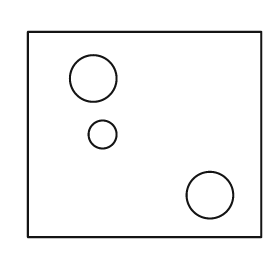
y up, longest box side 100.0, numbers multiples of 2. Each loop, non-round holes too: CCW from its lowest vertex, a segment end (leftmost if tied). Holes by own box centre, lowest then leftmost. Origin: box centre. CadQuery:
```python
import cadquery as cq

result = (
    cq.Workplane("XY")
    .moveTo(-50.0, -44.0)
    .lineTo(50.0, -44.0)
    .lineTo(50.0, 44.0)
    .lineTo(-50.0, 44.0)
    .close()
    .moveTo(28.0, -26.0)
    .circle(10.0)
    .moveTo(-18.0, 0.0)
    .circle(6.0)
    .moveTo(-22.0, 24.0)
    .circle(10.0)
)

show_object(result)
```